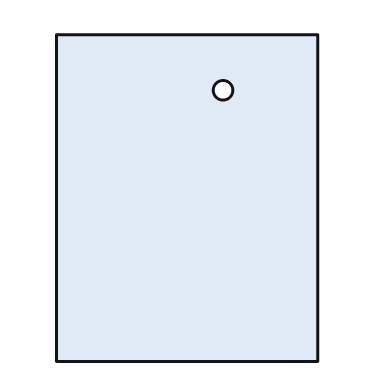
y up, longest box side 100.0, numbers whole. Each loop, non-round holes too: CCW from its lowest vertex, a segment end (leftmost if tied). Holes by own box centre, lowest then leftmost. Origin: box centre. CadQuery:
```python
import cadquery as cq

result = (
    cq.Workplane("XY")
    .moveTo(-40.0, -50.0)
    .lineTo(40.0, -50.0)
    .lineTo(40.0, 50.0)
    .lineTo(-40.0, 50.0)
    .close()
    .moveTo(11.0, 33.0)
    .circle(3.0)
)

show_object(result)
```